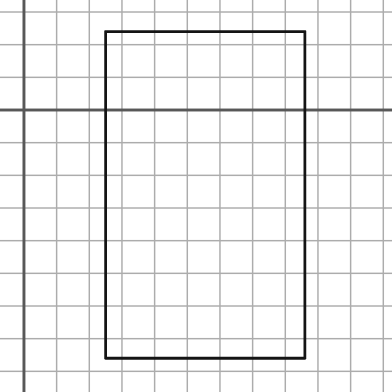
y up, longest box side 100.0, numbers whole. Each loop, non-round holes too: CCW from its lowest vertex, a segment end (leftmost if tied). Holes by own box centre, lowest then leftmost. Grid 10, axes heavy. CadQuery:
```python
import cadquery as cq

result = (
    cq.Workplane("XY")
    .moveTo(25.0, -76.0)
    .lineTo(86.0, -76.0)
    .lineTo(86.0, 24.0)
    .lineTo(25.0, 24.0)
    .close()
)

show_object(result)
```